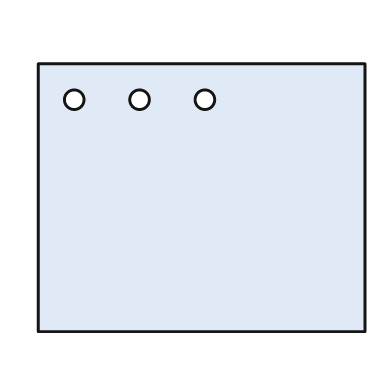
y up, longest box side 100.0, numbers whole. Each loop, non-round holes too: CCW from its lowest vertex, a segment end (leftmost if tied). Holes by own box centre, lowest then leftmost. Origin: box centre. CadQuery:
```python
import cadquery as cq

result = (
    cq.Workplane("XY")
    .moveTo(-50.0, -41.0)
    .lineTo(50.0, -41.0)
    .lineTo(50.0, 41.0)
    .lineTo(-50.0, 41.0)
    .close()
    .moveTo(-39.0, 30.0)
    .circle(3.0)
    .moveTo(-19.0, 30.0)
    .circle(3.0)
    .moveTo(1.0, 30.0)
    .circle(3.0)
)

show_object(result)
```